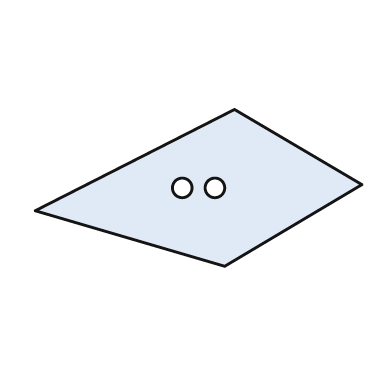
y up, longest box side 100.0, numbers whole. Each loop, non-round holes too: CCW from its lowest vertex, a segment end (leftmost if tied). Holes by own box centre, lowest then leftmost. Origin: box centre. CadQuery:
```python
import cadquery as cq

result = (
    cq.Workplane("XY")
    .moveTo(8.0, -24.0)
    .lineTo(50.0, 1.0)
    .lineTo(11.0, 24.0)
    .lineTo(-50.0, -7.0)
    .close()
    .moveTo(-5.0, 0.0)
    .circle(3.0)
    .moveTo(5.0, 0.0)
    .circle(3.0)
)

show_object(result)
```